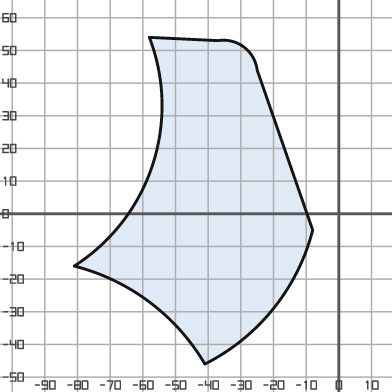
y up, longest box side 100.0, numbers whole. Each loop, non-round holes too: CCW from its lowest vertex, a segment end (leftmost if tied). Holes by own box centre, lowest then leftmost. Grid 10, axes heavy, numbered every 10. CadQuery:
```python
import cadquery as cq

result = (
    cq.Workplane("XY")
    .moveTo(-41.0, -46.0)
    .threePointArc((-20.0, -29.0), (-8.0, -5.0))
    .lineTo(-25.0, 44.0)
    .threePointArc((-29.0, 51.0), (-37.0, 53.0))
    .lineTo(-58.0, 54.0)
    .threePointArc((-57.0, 15.0), (-81.0, -16.0))
    .threePointArc((-58.0, -27.0), (-41.0, -46.0))
    .close()
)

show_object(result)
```